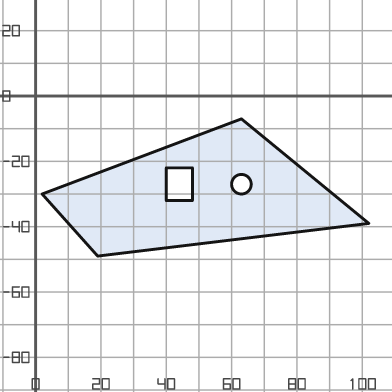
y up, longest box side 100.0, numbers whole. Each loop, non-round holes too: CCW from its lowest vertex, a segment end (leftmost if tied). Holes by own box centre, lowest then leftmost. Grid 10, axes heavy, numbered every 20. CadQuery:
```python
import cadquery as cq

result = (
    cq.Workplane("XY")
    .moveTo(19.0, -49.0)
    .lineTo(102.0, -39.0)
    .lineTo(63.0, -7.0)
    .lineTo(2.0, -30.0)
    .close()
    .moveTo(40.0, -32.0)
    .lineTo(48.0, -32.0)
    .lineTo(48.0, -22.0)
    .lineTo(40.0, -22.0)
    .close()
    .moveTo(63.0, -27.0)
    .circle(3.0)
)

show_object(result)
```